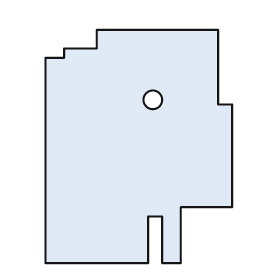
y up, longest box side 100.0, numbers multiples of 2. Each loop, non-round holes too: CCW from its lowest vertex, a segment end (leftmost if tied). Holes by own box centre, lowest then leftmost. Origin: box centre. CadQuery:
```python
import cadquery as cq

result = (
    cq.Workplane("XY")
    .moveTo(-40.0, -50.0)
    .lineTo(4.0, -50.0)
    .lineTo(4.0, -30.0)
    .lineTo(10.0, -30.0)
    .lineTo(10.0, -50.0)
    .lineTo(18.0, -50.0)
    .lineTo(18.0, -26.0)
    .lineTo(40.0, -26.0)
    .lineTo(40.0, 18.0)
    .lineTo(34.0, 18.0)
    .lineTo(34.0, 50.0)
    .lineTo(-18.0, 50.0)
    .lineTo(-18.0, 42.0)
    .lineTo(-32.0, 42.0)
    .lineTo(-32.0, 38.0)
    .lineTo(-40.0, 38.0)
    .close()
    .moveTo(6.0, 20.0)
    .circle(4.0)
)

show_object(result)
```